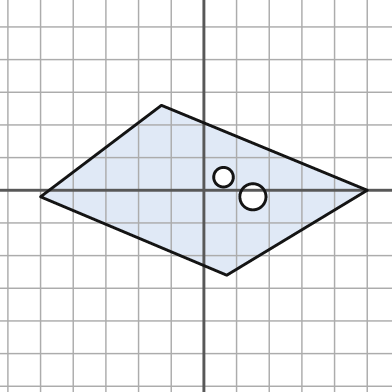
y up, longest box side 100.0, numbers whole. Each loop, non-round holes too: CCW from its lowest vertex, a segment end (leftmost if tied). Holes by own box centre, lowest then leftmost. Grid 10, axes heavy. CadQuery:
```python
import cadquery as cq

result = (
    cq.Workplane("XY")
    .moveTo(7.0, -26.0)
    .lineTo(50.0, 0.0)
    .lineTo(-13.0, 26.0)
    .lineTo(-50.0, -2.0)
    .close()
    .moveTo(15.0, -2.0)
    .circle(4.0)
    .moveTo(6.0, 4.0)
    .circle(3.0)
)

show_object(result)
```